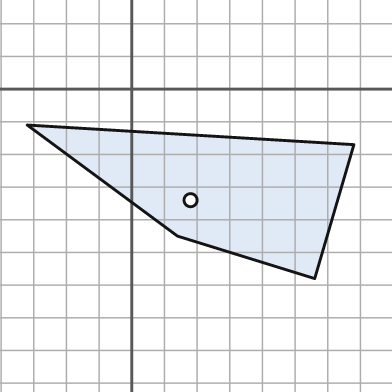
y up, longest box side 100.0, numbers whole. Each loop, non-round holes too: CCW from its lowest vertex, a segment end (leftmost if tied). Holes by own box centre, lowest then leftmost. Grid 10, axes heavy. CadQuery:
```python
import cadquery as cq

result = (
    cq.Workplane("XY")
    .moveTo(56.0, -58.0)
    .lineTo(68.0, -17.0)
    .lineTo(-32.0, -11.0)
    .lineTo(14.0, -45.0)
    .close()
    .moveTo(18.0, -34.0)
    .circle(2.0)
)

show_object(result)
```